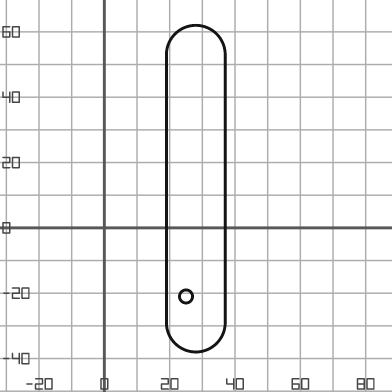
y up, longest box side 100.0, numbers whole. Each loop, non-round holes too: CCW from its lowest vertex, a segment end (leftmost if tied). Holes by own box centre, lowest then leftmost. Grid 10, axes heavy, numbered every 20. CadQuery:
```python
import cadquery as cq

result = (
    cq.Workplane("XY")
    .moveTo(19.0, -29.0)
    .threePointArc((28.0, -38.0), (37.0, -29.0))
    .lineTo(37.0, 53.0)
    .threePointArc((28.0, 62.0), (19.0, 53.0))
    .close()
    .moveTo(25.0, -21.0)
    .circle(2.0)
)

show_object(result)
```